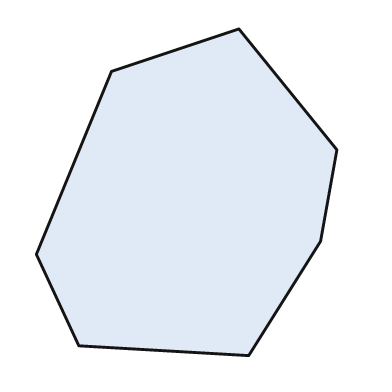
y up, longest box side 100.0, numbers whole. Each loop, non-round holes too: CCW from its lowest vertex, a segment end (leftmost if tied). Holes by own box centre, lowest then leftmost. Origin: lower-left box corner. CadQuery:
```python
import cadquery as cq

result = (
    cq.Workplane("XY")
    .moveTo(65.0, 0.0)
    .lineTo(87.0, 35.0)
    .lineTo(92.0, 63.0)
    .lineTo(62.0, 100.0)
    .lineTo(23.0, 87.0)
    .lineTo(0.0, 31.0)
    .lineTo(13.0, 3.0)
    .close()
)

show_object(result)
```